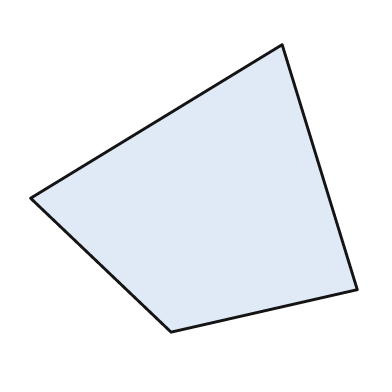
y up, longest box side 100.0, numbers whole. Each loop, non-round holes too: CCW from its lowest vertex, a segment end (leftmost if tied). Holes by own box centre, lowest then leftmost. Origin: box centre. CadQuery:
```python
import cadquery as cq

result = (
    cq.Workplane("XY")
    .moveTo(-7.0, -44.0)
    .lineTo(50.0, -31.0)
    .lineTo(27.0, 44.0)
    .lineTo(-50.0, -3.0)
    .close()
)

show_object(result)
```